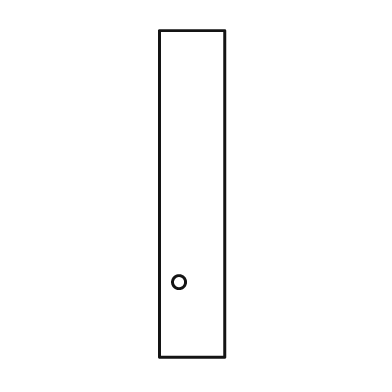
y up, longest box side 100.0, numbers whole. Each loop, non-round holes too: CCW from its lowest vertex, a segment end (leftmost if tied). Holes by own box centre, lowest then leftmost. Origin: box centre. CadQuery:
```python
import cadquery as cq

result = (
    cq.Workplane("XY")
    .moveTo(-10.0, -50.0)
    .lineTo(10.0, -50.0)
    .lineTo(10.0, 50.0)
    .lineTo(-10.0, 50.0)
    .close()
    .moveTo(-4.0, -27.0)
    .circle(2.0)
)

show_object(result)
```